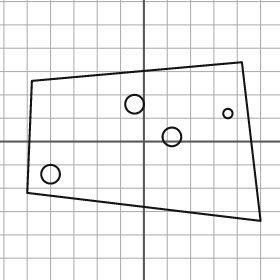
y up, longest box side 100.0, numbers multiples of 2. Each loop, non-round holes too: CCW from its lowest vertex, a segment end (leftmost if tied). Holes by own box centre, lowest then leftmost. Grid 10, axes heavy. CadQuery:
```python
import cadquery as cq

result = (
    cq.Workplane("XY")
    .moveTo(50.0, -34.0)
    .lineTo(42.0, 34.0)
    .lineTo(-48.0, 26.0)
    .lineTo(-50.0, -22.0)
    .close()
    .moveTo(-40.0, -14.0)
    .circle(4.0)
    .moveTo(12.0, 2.0)
    .circle(4.0)
    .moveTo(36.0, 12.0)
    .circle(2.0)
    .moveTo(-4.0, 16.0)
    .circle(4.0)
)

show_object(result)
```